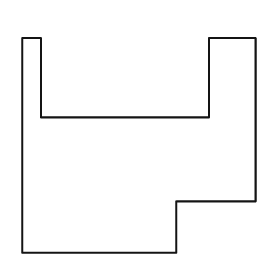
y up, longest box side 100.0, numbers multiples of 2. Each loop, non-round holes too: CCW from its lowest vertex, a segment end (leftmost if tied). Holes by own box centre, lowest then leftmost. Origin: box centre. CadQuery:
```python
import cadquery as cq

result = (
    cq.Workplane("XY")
    .moveTo(-50.0, -46.0)
    .lineTo(16.0, -46.0)
    .lineTo(16.0, -24.0)
    .lineTo(50.0, -24.0)
    .lineTo(50.0, 46.0)
    .lineTo(30.0, 46.0)
    .lineTo(30.0, 12.0)
    .lineTo(-42.0, 12.0)
    .lineTo(-42.0, 46.0)
    .lineTo(-50.0, 46.0)
    .close()
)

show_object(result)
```